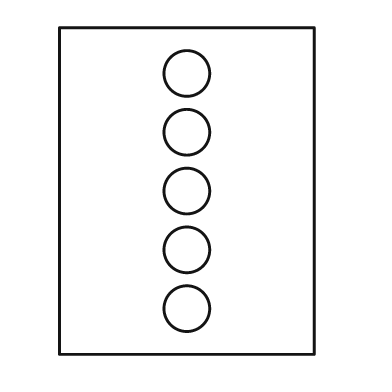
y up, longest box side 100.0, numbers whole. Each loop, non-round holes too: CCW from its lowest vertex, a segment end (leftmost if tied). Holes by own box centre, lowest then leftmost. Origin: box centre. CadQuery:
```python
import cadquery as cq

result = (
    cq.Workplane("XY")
    .moveTo(-39.0, -50.0)
    .lineTo(39.0, -50.0)
    .lineTo(39.0, 50.0)
    .lineTo(-39.0, 50.0)
    .close()
    .moveTo(0.0, -36.0)
    .circle(7.0)
    .moveTo(0.0, -18.0)
    .circle(7.0)
    .moveTo(0.0, 0.0)
    .circle(7.0)
    .moveTo(0.0, 18.0)
    .circle(7.0)
    .moveTo(0.0, 36.0)
    .circle(7.0)
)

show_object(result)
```